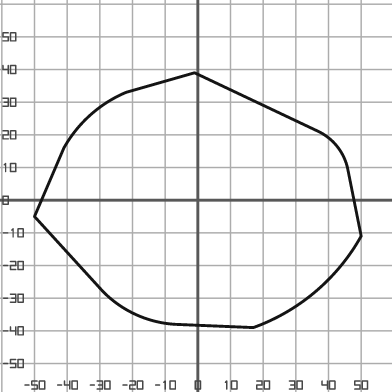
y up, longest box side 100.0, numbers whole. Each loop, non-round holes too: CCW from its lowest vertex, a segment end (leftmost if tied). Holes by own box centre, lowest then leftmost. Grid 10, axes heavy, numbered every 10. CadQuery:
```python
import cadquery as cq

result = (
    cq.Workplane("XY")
    .moveTo(17.0, -39.0)
    .threePointArc((36.0, -28.0), (50.0, -11.0))
    .lineTo(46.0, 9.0)
    .threePointArc((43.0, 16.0), (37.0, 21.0))
    .lineTo(-1.0, 39.0)
    .lineTo(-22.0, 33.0)
    .threePointArc((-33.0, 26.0), (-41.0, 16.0))
    .lineTo(-50.0, -5.0)
    .lineTo(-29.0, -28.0)
    .threePointArc((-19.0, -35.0), (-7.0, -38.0))
    .close()
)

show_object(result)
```